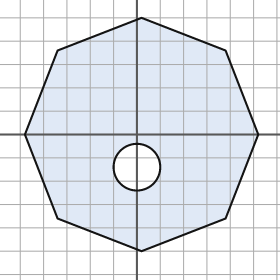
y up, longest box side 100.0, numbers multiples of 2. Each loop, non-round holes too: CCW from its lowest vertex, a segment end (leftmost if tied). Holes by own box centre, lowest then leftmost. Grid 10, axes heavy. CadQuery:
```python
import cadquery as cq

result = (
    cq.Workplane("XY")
    .moveTo(2.0, -50.0)
    .lineTo(38.0, -36.0)
    .lineTo(52.0, 0.0)
    .lineTo(38.0, 36.0)
    .lineTo(2.0, 50.0)
    .lineTo(-34.0, 36.0)
    .lineTo(-48.0, 0.0)
    .lineTo(-34.0, -36.0)
    .close()
    .moveTo(0.0, -14.0)
    .circle(10.0)
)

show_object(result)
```